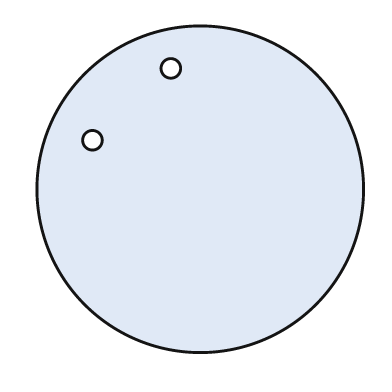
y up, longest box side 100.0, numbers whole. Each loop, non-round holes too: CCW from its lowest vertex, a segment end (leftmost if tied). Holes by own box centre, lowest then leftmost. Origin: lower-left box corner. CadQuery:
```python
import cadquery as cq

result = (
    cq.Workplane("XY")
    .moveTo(50.0, 50.0)
    .circle(50.0)
    .moveTo(17.0, 65.0)
    .circle(3.0)
    .moveTo(41.0, 87.0)
    .circle(3.0)
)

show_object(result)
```